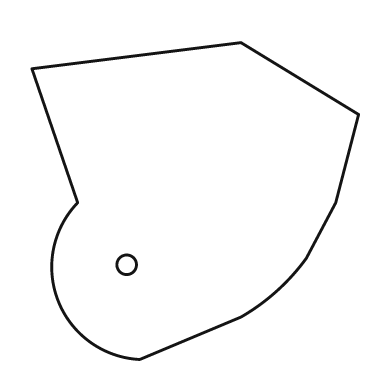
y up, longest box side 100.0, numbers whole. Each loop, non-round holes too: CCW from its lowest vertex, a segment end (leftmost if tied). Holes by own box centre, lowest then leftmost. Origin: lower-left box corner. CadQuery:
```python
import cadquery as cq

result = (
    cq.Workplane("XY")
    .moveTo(33.0, 0.0)
    .lineTo(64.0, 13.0)
    .threePointArc((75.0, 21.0), (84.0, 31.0))
    .lineTo(93.0, 48.0)
    .lineTo(100.0, 75.0)
    .lineTo(64.0, 97.0)
    .lineTo(0.0, 89.0)
    .lineTo(14.0, 48.0)
    .threePointArc((8.0, 18.0), (33.0, 0.0))
    .close()
    .moveTo(29.0, 29.0)
    .circle(3.0)
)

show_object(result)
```